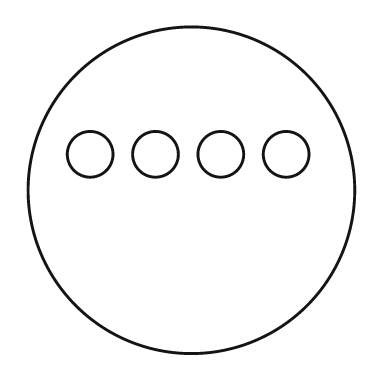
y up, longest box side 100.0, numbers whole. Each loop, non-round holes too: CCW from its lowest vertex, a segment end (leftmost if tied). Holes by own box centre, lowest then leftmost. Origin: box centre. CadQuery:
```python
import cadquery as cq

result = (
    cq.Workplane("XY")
    .moveTo(0.0, 0.0)
    .circle(50.0)
    .moveTo(-31.0, 11.0)
    .circle(7.0)
    .moveTo(-11.0, 11.0)
    .circle(7.0)
    .moveTo(9.0, 11.0)
    .circle(7.0)
    .moveTo(29.0, 11.0)
    .circle(7.0)
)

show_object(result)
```